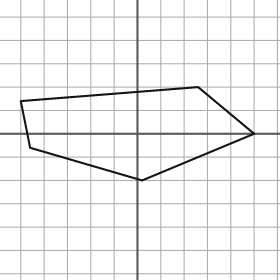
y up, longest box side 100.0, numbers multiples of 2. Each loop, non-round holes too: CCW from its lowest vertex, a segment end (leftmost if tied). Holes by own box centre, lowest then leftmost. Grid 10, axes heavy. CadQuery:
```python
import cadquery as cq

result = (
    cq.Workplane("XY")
    .moveTo(2.0, -20.0)
    .lineTo(50.0, 0.0)
    .lineTo(26.0, 20.0)
    .lineTo(-50.0, 14.0)
    .lineTo(-46.0, -6.0)
    .close()
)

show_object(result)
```